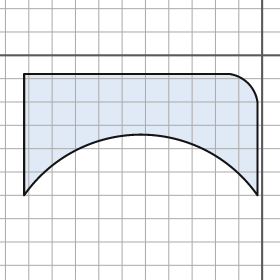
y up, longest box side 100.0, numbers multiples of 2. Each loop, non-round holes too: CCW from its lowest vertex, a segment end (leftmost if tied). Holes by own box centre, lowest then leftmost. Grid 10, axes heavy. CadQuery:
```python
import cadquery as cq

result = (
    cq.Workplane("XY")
    .moveTo(-102.0, -60.0)
    .threePointArc((-52.0, -34.0), (-2.0, -60.0))
    .lineTo(-2.0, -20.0)
    .threePointArc((-6.0, -12.0), (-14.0, -8.0))
    .lineTo(-102.0, -8.0)
    .close()
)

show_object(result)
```